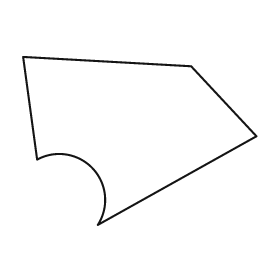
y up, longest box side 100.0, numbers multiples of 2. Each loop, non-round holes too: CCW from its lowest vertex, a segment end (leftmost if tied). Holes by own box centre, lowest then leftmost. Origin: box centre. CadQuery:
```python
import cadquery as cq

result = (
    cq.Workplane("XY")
    .moveTo(-18.0, -36.0)
    .lineTo(50.0, 2.0)
    .lineTo(22.0, 32.0)
    .lineTo(-50.0, 36.0)
    .lineTo(-44.0, -8.0)
    .threePointArc((-20.0, -12.0), (-18.0, -36.0))
    .close()
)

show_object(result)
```